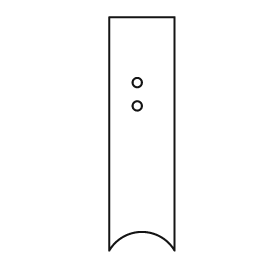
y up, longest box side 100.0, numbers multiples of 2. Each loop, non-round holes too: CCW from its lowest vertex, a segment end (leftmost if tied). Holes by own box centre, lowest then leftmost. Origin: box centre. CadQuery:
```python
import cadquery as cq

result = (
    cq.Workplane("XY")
    .moveTo(-14.0, -50.0)
    .threePointArc((0.0, -42.0), (14.0, -50.0))
    .lineTo(14.0, 50.0)
    .lineTo(-14.0, 50.0)
    .close()
    .moveTo(-2.0, 12.0)
    .circle(2.0)
    .moveTo(-2.0, 22.0)
    .circle(2.0)
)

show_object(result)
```